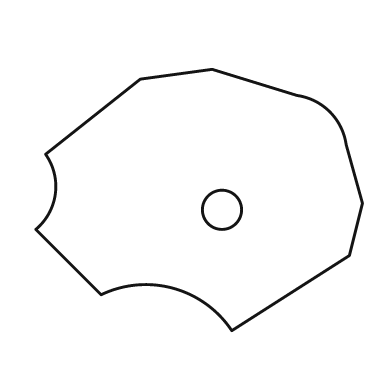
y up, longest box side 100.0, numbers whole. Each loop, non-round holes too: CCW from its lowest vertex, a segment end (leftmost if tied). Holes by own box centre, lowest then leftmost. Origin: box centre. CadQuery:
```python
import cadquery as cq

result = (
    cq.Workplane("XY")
    .moveTo(10.0, -40.0)
    .lineTo(46.0, -17.0)
    .lineTo(50.0, -1.0)
    .lineTo(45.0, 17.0)
    .threePointArc((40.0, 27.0), (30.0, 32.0))
    .lineTo(4.0, 40.0)
    .lineTo(-18.0, 37.0)
    .lineTo(-47.0, 14.0)
    .threePointArc((-44.0, 2.0), (-50.0, -9.0))
    .lineTo(-30.0, -29.0)
    .threePointArc((-8.0, -27.0), (10.0, -40.0))
    .close()
    .moveTo(7.0, -3.0)
    .circle(6.0)
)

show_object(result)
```